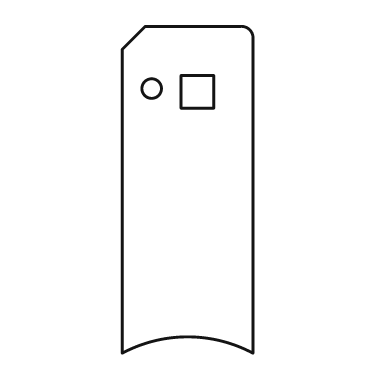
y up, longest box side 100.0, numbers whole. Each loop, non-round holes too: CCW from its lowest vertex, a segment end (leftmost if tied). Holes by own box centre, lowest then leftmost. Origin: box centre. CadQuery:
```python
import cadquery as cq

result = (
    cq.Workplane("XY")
    .moveTo(-20.0, -50.0)
    .threePointArc((0.0, -45.0), (20.0, -50.0))
    .lineTo(20.0, 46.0)
    .threePointArc((19.0, 49.0), (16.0, 50.0))
    .lineTo(-13.0, 50.0)
    .lineTo(-20.0, 43.0)
    .close()
    .moveTo(-2.0, 25.0)
    .lineTo(8.0, 25.0)
    .lineTo(8.0, 35.0)
    .lineTo(-2.0, 35.0)
    .close()
    .moveTo(-11.0, 31.0)
    .circle(3.0)
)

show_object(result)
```